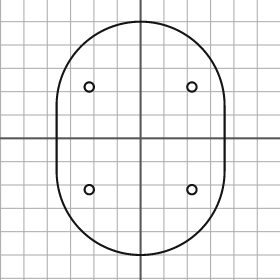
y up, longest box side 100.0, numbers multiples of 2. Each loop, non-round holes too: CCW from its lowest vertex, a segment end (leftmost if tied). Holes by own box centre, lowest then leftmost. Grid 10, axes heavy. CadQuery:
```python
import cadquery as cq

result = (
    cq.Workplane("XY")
    .moveTo(-36.0, -14.0)
    .threePointArc((0.0, -50.0), (36.0, -14.0))
    .lineTo(36.0, 14.0)
    .threePointArc((0.0, 50.0), (-36.0, 14.0))
    .close()
    .moveTo(-22.0, -22.0)
    .circle(2.0)
    .moveTo(22.0, -22.0)
    .circle(2.0)
    .moveTo(-22.0, 22.0)
    .circle(2.0)
    .moveTo(22.0, 22.0)
    .circle(2.0)
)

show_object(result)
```